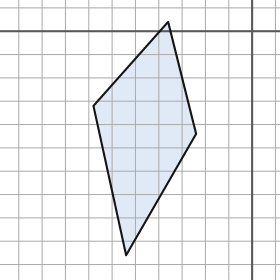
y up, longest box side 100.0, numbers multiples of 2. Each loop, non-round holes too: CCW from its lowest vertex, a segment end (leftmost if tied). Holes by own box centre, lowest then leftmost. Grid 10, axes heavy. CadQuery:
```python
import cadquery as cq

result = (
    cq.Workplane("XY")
    .moveTo(-54.0, -96.0)
    .lineTo(-24.0, -44.0)
    .lineTo(-36.0, 4.0)
    .lineTo(-68.0, -32.0)
    .close()
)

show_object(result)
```